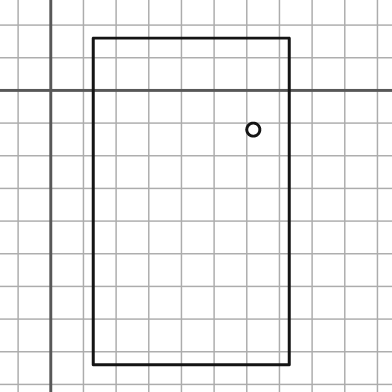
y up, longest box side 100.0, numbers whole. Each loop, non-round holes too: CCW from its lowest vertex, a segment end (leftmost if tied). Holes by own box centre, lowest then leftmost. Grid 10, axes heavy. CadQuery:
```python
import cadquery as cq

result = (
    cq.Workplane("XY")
    .moveTo(13.0, -84.0)
    .lineTo(73.0, -84.0)
    .lineTo(73.0, 16.0)
    .lineTo(13.0, 16.0)
    .close()
    .moveTo(62.0, -12.0)
    .circle(2.0)
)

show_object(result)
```